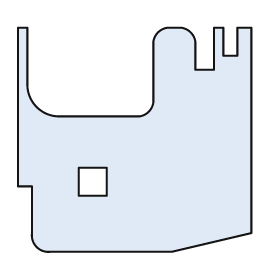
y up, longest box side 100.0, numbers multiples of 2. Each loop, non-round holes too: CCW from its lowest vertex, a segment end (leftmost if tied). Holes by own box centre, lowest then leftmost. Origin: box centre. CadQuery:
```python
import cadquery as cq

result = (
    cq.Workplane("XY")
    .moveTo(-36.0, -48.0)
    .lineTo(16.0, -48.0)
    .lineTo(50.0, -40.0)
    .lineTo(50.0, 48.0)
    .lineTo(44.0, 48.0)
    .lineTo(44.0, 36.0)
    .lineTo(38.0, 36.0)
    .lineTo(38.0, 48.0)
    .lineTo(34.0, 48.0)
    .lineTo(34.0, 30.0)
    .lineTo(26.0, 30.0)
    .lineTo(26.0, 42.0)
    .threePointArc((24.0, 46.0), (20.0, 48.0))
    .lineTo(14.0, 48.0)
    .threePointArc((10.0, 46.0), (8.0, 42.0))
    .lineTo(8.0, 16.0)
    .threePointArc((6.0, 12.0), (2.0, 10.0))
    .lineTo(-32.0, 10.0)
    .threePointArc((-42.0, 14.0), (-46.0, 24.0))
    .lineTo(-46.0, 48.0)
    .lineTo(-50.0, 48.0)
    .lineTo(-50.0, -20.0)
    .lineTo(-44.0, -20.0)
    .lineTo(-44.0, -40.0)
    .threePointArc((-42.0, -46.0), (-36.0, -48.0))
    .close()
    .moveTo(-24.0, -24.0)
    .lineTo(-12.0, -24.0)
    .lineTo(-12.0, -12.0)
    .lineTo(-24.0, -12.0)
    .close()
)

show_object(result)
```